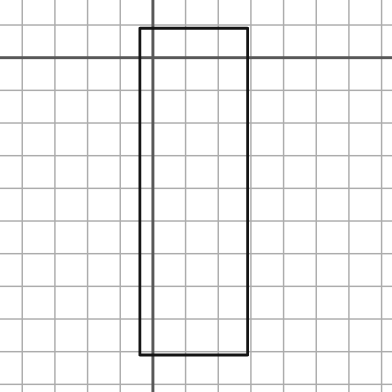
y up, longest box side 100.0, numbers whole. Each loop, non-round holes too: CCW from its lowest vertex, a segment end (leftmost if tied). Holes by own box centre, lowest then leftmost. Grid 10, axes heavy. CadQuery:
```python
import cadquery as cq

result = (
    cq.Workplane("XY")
    .moveTo(-4.0, -91.0)
    .lineTo(29.0, -91.0)
    .lineTo(29.0, 9.0)
    .lineTo(-4.0, 9.0)
    .close()
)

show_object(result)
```